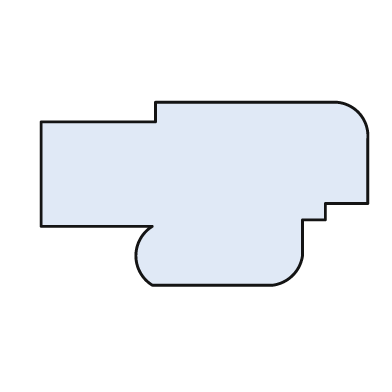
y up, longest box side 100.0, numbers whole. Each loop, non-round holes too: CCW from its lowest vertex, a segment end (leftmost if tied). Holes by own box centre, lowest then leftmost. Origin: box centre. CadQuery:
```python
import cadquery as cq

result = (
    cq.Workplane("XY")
    .moveTo(-16.0, -28.0)
    .lineTo(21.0, -28.0)
    .threePointArc((27.0, -25.0), (30.0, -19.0))
    .lineTo(30.0, -8.0)
    .lineTo(37.0, -8.0)
    .lineTo(37.0, -3.0)
    .lineTo(50.0, -3.0)
    .lineTo(50.0, 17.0)
    .threePointArc((47.0, 25.0), (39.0, 28.0))
    .lineTo(-15.0, 28.0)
    .lineTo(-15.0, 22.0)
    .lineTo(-50.0, 22.0)
    .lineTo(-50.0, -10.0)
    .lineTo(-16.0, -10.0)
    .threePointArc((-21.0, -19.0), (-16.0, -28.0))
    .close()
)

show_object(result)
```